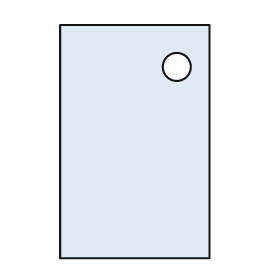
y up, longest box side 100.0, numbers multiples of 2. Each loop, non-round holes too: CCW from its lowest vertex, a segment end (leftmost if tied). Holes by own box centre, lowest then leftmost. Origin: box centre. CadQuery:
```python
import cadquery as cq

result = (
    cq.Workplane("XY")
    .moveTo(-32.0, -50.0)
    .lineTo(32.0, -50.0)
    .lineTo(32.0, 50.0)
    .lineTo(-32.0, 50.0)
    .close()
    .moveTo(18.0, 32.0)
    .circle(6.0)
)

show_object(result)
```